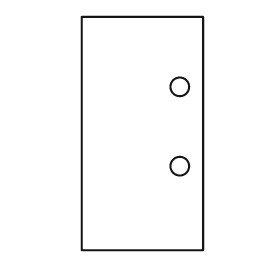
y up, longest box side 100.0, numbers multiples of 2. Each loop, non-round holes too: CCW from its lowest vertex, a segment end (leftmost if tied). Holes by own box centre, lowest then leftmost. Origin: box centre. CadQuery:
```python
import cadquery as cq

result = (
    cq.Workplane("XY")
    .moveTo(-26.0, -50.0)
    .lineTo(26.0, -50.0)
    .lineTo(26.0, 50.0)
    .lineTo(-26.0, 50.0)
    .close()
    .moveTo(16.0, -14.0)
    .circle(4.0)
    .moveTo(16.0, 20.0)
    .circle(4.0)
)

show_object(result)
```